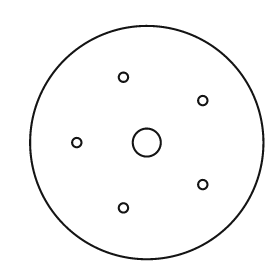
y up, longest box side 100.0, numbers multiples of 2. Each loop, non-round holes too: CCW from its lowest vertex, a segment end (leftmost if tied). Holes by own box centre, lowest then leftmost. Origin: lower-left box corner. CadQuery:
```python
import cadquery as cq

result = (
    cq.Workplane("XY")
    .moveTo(50.0, 50.0)
    .circle(50.0)
    .moveTo(40.0, 22.0)
    .circle(2.0)
    .moveTo(74.0, 32.0)
    .circle(2.0)
    .moveTo(20.0, 50.0)
    .circle(2.0)
    .moveTo(50.0, 50.0)
    .circle(6.0)
    .moveTo(74.0, 68.0)
    .circle(2.0)
    .moveTo(40.0, 78.0)
    .circle(2.0)
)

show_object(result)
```